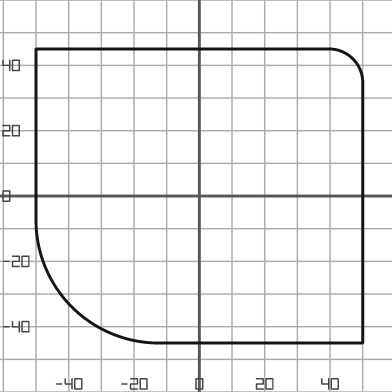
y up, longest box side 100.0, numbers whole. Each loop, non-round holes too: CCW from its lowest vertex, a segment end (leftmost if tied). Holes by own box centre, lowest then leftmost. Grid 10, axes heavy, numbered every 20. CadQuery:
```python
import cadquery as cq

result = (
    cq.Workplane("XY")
    .moveTo(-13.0, -45.0)
    .lineTo(50.0, -45.0)
    .lineTo(50.0, 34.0)
    .threePointArc((47.0, 42.0), (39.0, 45.0))
    .lineTo(-50.0, 45.0)
    .lineTo(-50.0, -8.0)
    .threePointArc((-39.0, -34.0), (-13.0, -45.0))
    .close()
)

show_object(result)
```